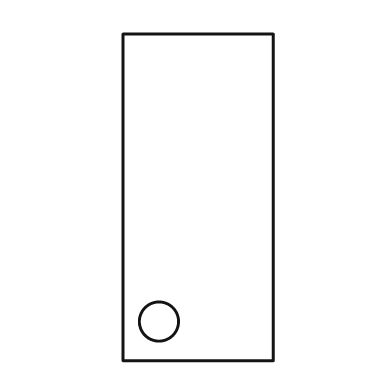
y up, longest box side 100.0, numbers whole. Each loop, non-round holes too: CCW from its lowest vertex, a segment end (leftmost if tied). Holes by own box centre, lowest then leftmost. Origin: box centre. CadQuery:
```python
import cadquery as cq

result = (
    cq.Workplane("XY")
    .moveTo(-23.0, -50.0)
    .lineTo(23.0, -50.0)
    .lineTo(23.0, 50.0)
    .lineTo(-23.0, 50.0)
    .close()
    .moveTo(-12.0, -38.0)
    .circle(6.0)
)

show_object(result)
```